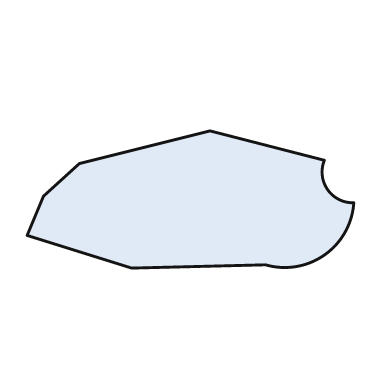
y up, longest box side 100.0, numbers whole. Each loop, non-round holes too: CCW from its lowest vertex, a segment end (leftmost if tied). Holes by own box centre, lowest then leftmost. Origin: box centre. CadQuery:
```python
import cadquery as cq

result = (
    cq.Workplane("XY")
    .moveTo(-18.0, -21.0)
    .lineTo(23.0, -20.0)
    .threePointArc((41.0, -17.0), (50.0, -1.0))
    .threePointArc((42.0, 3.0), (41.0, 12.0))
    .lineTo(6.0, 21.0)
    .lineTo(-34.0, 11.0)
    .lineTo(-45.0, 1.0)
    .lineTo(-50.0, -11.0)
    .close()
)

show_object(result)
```